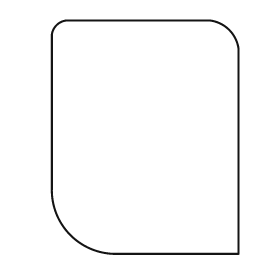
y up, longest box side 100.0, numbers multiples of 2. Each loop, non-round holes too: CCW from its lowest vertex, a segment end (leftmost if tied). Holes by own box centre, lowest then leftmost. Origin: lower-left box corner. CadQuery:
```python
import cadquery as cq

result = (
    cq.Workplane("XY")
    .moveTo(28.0, 0.0)
    .lineTo(80.0, 0.0)
    .lineTo(80.0, 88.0)
    .threePointArc((76.0, 96.0), (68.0, 100.0))
    .lineTo(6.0, 100.0)
    .threePointArc((2.0, 98.0), (0.0, 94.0))
    .lineTo(0.0, 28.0)
    .threePointArc((8.0, 8.0), (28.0, 0.0))
    .close()
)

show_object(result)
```